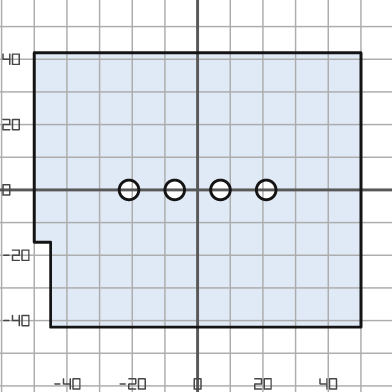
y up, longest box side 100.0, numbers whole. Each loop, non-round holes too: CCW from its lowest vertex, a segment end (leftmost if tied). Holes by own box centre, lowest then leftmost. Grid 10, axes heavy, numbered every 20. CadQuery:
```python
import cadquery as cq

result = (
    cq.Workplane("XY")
    .moveTo(-45.0, -42.0)
    .lineTo(50.0, -42.0)
    .lineTo(50.0, 42.0)
    .lineTo(-50.0, 42.0)
    .lineTo(-50.0, -16.0)
    .lineTo(-45.0, -16.0)
    .close()
    .moveTo(-21.0, 0.0)
    .circle(3.0)
    .moveTo(-7.0, 0.0)
    .circle(3.0)
    .moveTo(7.0, 0.0)
    .circle(3.0)
    .moveTo(21.0, 0.0)
    .circle(3.0)
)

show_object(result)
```